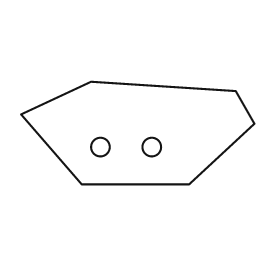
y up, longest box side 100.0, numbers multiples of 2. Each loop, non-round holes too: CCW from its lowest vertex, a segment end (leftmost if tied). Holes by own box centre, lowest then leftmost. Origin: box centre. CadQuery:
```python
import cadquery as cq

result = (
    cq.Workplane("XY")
    .moveTo(-24.0, -22.0)
    .lineTo(22.0, -22.0)
    .lineTo(50.0, 4.0)
    .lineTo(42.0, 18.0)
    .lineTo(-20.0, 22.0)
    .lineTo(-50.0, 8.0)
    .close()
    .moveTo(-16.0, -6.0)
    .circle(4.0)
    .moveTo(6.0, -6.0)
    .circle(4.0)
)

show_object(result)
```